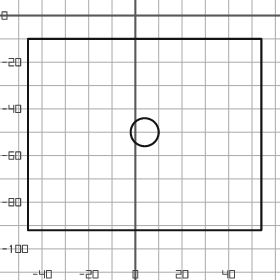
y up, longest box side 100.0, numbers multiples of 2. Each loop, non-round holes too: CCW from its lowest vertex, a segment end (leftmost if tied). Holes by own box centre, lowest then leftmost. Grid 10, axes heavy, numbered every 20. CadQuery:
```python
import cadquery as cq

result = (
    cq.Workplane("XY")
    .moveTo(-46.0, -92.0)
    .lineTo(54.0, -92.0)
    .lineTo(54.0, -10.0)
    .lineTo(-46.0, -10.0)
    .close()
    .moveTo(4.0, -50.0)
    .circle(6.0)
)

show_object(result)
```